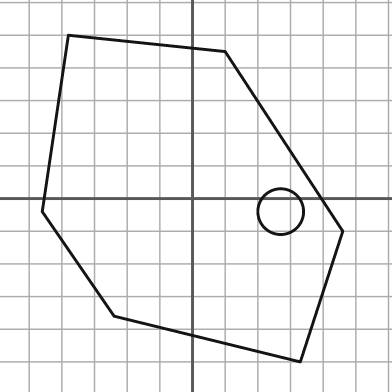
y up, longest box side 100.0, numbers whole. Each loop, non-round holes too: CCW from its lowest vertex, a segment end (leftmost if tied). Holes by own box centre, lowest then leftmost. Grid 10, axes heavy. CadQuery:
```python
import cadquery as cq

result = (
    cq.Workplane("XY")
    .moveTo(33.0, -50.0)
    .lineTo(46.0, -10.0)
    .lineTo(10.0, 45.0)
    .lineTo(-38.0, 50.0)
    .lineTo(-46.0, -4.0)
    .lineTo(-24.0, -36.0)
    .close()
    .moveTo(27.0, -4.0)
    .circle(7.0)
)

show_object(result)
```